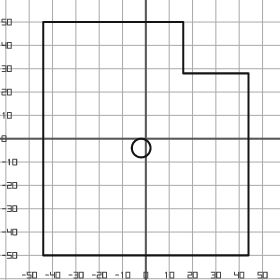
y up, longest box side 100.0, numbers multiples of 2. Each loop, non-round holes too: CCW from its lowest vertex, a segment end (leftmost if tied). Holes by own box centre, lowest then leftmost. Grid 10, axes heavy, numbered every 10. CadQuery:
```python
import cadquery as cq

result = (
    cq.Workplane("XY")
    .moveTo(-44.0, -50.0)
    .lineTo(44.0, -50.0)
    .lineTo(44.0, 28.0)
    .lineTo(16.0, 28.0)
    .lineTo(16.0, 50.0)
    .lineTo(-44.0, 50.0)
    .close()
    .moveTo(-2.0, -4.0)
    .circle(4.0)
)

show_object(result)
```